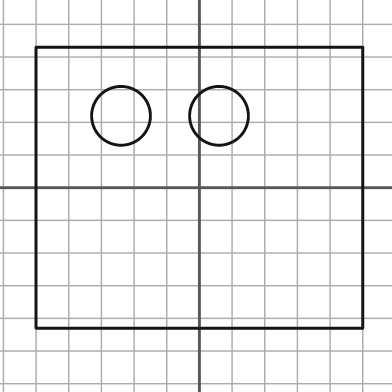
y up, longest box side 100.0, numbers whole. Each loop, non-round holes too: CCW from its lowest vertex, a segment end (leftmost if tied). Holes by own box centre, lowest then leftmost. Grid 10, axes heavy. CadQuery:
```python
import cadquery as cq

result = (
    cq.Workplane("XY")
    .moveTo(-50.0, -43.0)
    .lineTo(50.0, -43.0)
    .lineTo(50.0, 43.0)
    .lineTo(-50.0, 43.0)
    .close()
    .moveTo(-24.0, 22.0)
    .circle(9.0)
    .moveTo(6.0, 22.0)
    .circle(9.0)
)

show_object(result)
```